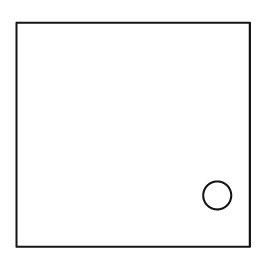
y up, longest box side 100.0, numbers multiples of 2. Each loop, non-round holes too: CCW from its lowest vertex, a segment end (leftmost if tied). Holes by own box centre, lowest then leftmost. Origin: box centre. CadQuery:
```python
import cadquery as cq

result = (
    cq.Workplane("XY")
    .moveTo(-50.0, -48.0)
    .lineTo(50.0, -48.0)
    .lineTo(50.0, 48.0)
    .lineTo(-50.0, 48.0)
    .close()
    .moveTo(36.0, -26.0)
    .circle(6.0)
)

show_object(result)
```